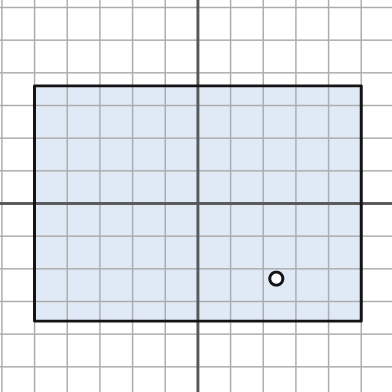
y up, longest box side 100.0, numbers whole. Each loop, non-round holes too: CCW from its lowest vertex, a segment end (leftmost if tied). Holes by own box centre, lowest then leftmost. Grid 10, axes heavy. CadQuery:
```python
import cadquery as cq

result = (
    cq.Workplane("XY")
    .moveTo(-50.0, -36.0)
    .lineTo(50.0, -36.0)
    .lineTo(50.0, 36.0)
    .lineTo(-50.0, 36.0)
    .close()
    .moveTo(24.0, -23.0)
    .circle(2.0)
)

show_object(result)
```